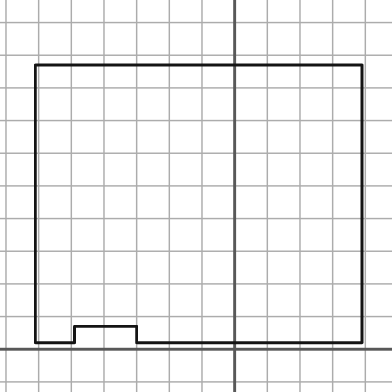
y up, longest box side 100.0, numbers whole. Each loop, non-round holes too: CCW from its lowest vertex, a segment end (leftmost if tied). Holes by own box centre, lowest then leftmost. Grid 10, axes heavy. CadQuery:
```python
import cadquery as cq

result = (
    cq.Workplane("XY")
    .moveTo(-61.0, 2.0)
    .lineTo(-49.0, 2.0)
    .lineTo(-49.0, 7.0)
    .lineTo(-30.0, 7.0)
    .lineTo(-30.0, 2.0)
    .lineTo(39.0, 2.0)
    .lineTo(39.0, 87.0)
    .lineTo(-61.0, 87.0)
    .close()
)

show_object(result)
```